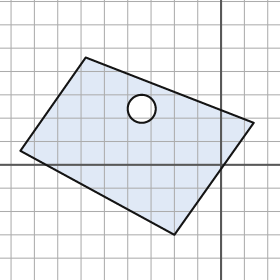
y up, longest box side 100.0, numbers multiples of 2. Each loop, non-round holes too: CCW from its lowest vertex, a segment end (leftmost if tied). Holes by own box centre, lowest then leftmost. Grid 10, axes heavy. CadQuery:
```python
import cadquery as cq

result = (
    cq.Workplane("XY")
    .moveTo(-20.0, -30.0)
    .lineTo(14.0, 18.0)
    .lineTo(-58.0, 46.0)
    .lineTo(-86.0, 6.0)
    .close()
    .moveTo(-34.0, 24.0)
    .circle(6.0)
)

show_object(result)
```